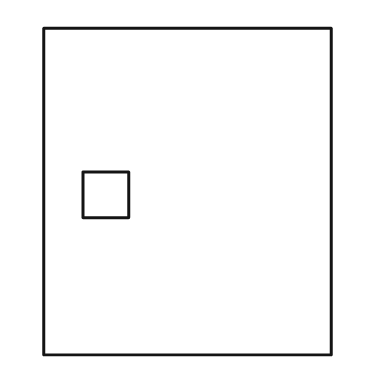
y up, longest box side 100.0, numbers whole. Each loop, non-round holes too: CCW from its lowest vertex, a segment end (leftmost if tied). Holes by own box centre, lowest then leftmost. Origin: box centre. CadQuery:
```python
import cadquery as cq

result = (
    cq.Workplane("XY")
    .moveTo(-44.0, -50.0)
    .lineTo(44.0, -50.0)
    .lineTo(44.0, 50.0)
    .lineTo(-44.0, 50.0)
    .close()
    .moveTo(-32.0, -8.0)
    .lineTo(-18.0, -8.0)
    .lineTo(-18.0, 6.0)
    .lineTo(-32.0, 6.0)
    .close()
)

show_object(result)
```